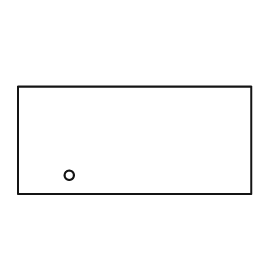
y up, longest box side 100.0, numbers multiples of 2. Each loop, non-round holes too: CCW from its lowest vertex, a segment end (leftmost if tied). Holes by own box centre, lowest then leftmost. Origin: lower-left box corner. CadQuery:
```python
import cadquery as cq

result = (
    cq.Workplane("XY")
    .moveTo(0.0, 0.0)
    .lineTo(100.0, 0.0)
    .lineTo(100.0, 46.0)
    .lineTo(0.0, 46.0)
    .close()
    .moveTo(22.0, 8.0)
    .circle(2.0)
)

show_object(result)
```